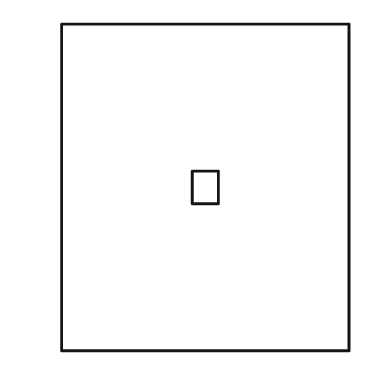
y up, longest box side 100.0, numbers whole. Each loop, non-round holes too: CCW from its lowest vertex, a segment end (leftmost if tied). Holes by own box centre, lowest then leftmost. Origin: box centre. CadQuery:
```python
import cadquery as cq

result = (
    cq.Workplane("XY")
    .moveTo(-44.0, -50.0)
    .lineTo(44.0, -50.0)
    .lineTo(44.0, 50.0)
    .lineTo(-44.0, 50.0)
    .close()
    .moveTo(-4.0, -5.0)
    .lineTo(4.0, -5.0)
    .lineTo(4.0, 5.0)
    .lineTo(-4.0, 5.0)
    .close()
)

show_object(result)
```